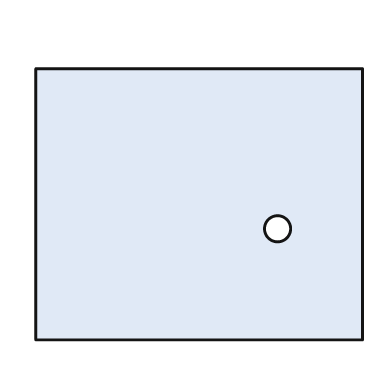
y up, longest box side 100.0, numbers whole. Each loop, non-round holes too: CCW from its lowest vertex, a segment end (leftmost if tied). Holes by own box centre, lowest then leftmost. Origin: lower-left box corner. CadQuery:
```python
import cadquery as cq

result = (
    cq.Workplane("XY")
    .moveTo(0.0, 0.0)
    .lineTo(100.0, 0.0)
    .lineTo(100.0, 83.0)
    .lineTo(0.0, 83.0)
    .close()
    .moveTo(74.0, 34.0)
    .circle(4.0)
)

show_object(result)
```